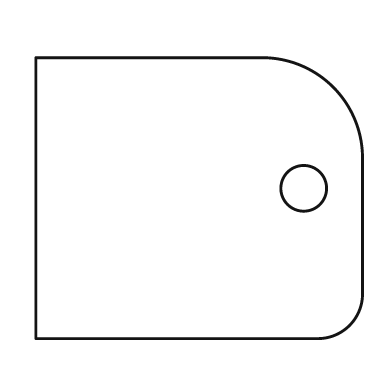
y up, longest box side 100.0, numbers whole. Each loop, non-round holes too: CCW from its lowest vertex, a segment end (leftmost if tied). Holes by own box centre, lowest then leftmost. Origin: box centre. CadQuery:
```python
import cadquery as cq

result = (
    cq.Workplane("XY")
    .moveTo(-50.0, -43.0)
    .lineTo(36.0, -43.0)
    .threePointArc((46.0, -39.0), (50.0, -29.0))
    .lineTo(50.0, 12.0)
    .threePointArc((41.0, 34.0), (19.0, 43.0))
    .lineTo(-50.0, 43.0)
    .close()
    .moveTo(32.0, 3.0)
    .circle(7.0)
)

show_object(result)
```